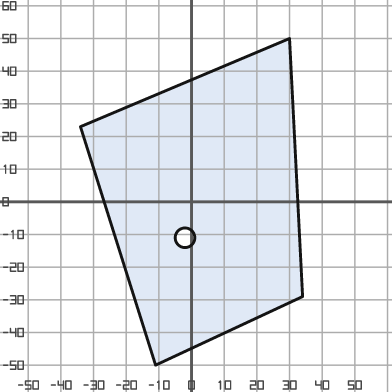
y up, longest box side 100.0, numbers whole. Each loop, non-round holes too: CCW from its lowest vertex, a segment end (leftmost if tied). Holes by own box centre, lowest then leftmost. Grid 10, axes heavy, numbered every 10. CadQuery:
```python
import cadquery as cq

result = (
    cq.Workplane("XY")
    .moveTo(-11.0, -50.0)
    .lineTo(34.0, -29.0)
    .lineTo(30.0, 50.0)
    .lineTo(-34.0, 23.0)
    .close()
    .moveTo(-2.0, -11.0)
    .circle(3.0)
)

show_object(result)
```